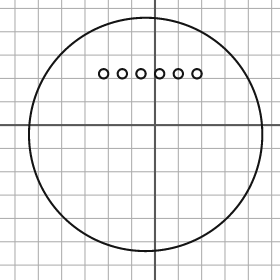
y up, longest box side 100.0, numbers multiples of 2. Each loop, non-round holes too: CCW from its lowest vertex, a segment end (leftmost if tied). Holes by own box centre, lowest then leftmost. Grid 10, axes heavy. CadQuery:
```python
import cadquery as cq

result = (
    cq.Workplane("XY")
    .moveTo(-4.0, -4.0)
    .circle(50.0)
    .moveTo(-22.0, 22.0)
    .circle(2.0)
    .moveTo(-14.0, 22.0)
    .circle(2.0)
    .moveTo(-6.0, 22.0)
    .circle(2.0)
    .moveTo(2.0, 22.0)
    .circle(2.0)
    .moveTo(10.0, 22.0)
    .circle(2.0)
    .moveTo(18.0, 22.0)
    .circle(2.0)
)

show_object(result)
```